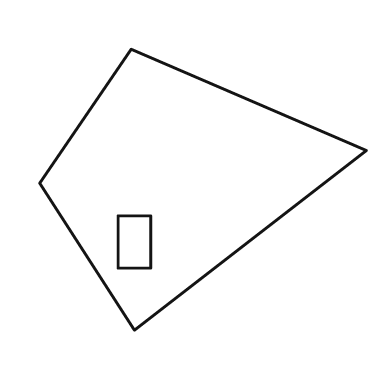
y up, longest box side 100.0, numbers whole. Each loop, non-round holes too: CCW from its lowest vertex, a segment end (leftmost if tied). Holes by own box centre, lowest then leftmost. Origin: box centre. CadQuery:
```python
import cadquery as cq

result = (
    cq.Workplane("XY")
    .moveTo(-21.0, -43.0)
    .lineTo(50.0, 12.0)
    .lineTo(-22.0, 43.0)
    .lineTo(-50.0, 2.0)
    .close()
    .moveTo(-26.0, -24.0)
    .lineTo(-16.0, -24.0)
    .lineTo(-16.0, -8.0)
    .lineTo(-26.0, -8.0)
    .close()
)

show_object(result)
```